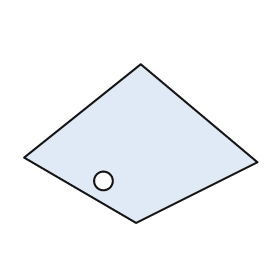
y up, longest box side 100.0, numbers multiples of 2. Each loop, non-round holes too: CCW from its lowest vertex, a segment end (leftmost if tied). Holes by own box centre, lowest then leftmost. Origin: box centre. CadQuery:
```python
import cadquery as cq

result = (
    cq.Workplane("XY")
    .moveTo(-2.0, -34.0)
    .lineTo(50.0, -8.0)
    .lineTo(0.0, 34.0)
    .lineTo(-50.0, -6.0)
    .close()
    .moveTo(-16.0, -16.0)
    .circle(4.0)
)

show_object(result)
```